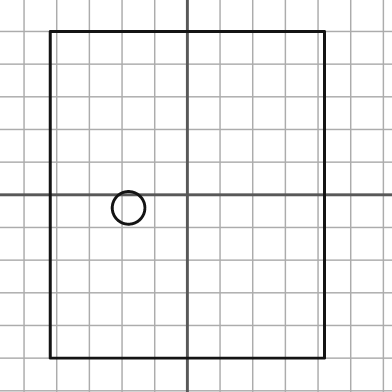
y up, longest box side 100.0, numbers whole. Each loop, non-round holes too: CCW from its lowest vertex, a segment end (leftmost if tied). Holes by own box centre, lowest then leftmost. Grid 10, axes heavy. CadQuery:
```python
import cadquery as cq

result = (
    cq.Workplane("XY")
    .moveTo(-42.0, -50.0)
    .lineTo(42.0, -50.0)
    .lineTo(42.0, 50.0)
    .lineTo(-42.0, 50.0)
    .close()
    .moveTo(-18.0, -4.0)
    .circle(5.0)
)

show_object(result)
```